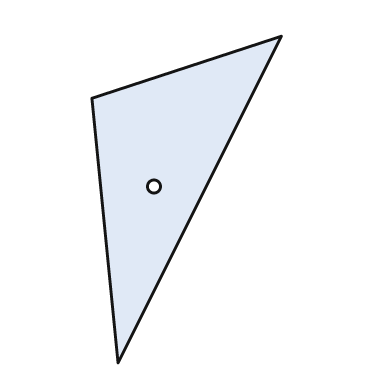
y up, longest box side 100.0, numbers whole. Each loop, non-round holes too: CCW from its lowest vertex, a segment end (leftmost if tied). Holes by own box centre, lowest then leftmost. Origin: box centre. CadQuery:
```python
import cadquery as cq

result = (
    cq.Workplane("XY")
    .moveTo(-21.0, -50.0)
    .lineTo(29.0, 50.0)
    .lineTo(-29.0, 31.0)
    .close()
    .moveTo(-10.0, 4.0)
    .circle(2.0)
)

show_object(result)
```